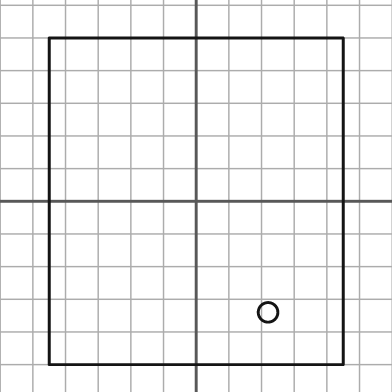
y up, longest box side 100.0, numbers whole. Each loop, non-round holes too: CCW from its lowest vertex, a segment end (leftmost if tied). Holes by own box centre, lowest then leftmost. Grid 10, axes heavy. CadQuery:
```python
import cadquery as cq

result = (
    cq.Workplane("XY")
    .moveTo(-45.0, -50.0)
    .lineTo(45.0, -50.0)
    .lineTo(45.0, 50.0)
    .lineTo(-45.0, 50.0)
    .close()
    .moveTo(22.0, -34.0)
    .circle(3.0)
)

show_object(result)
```